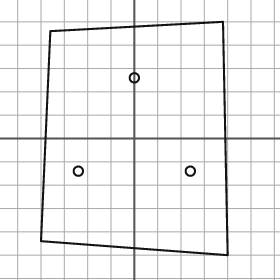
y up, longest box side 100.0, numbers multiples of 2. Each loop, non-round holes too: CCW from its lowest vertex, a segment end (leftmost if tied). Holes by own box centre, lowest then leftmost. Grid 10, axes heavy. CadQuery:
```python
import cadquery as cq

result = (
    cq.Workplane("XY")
    .moveTo(40.0, -50.0)
    .lineTo(38.0, 50.0)
    .lineTo(-36.0, 46.0)
    .lineTo(-40.0, -44.0)
    .close()
    .moveTo(-24.0, -14.0)
    .circle(2.0)
    .moveTo(24.0, -14.0)
    .circle(2.0)
    .moveTo(0.0, 26.0)
    .circle(2.0)
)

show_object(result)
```